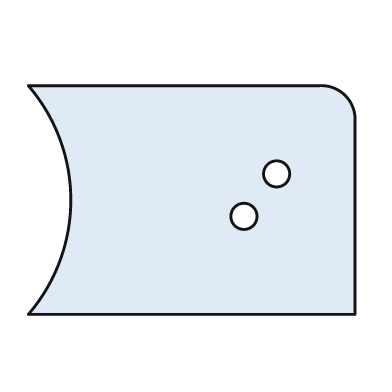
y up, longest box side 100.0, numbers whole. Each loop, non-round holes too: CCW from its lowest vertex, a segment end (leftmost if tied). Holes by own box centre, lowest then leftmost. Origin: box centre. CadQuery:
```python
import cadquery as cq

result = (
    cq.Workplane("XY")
    .moveTo(-50.0, -35.0)
    .lineTo(50.0, -35.0)
    .lineTo(50.0, 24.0)
    .threePointArc((47.0, 32.0), (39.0, 35.0))
    .lineTo(-50.0, 35.0)
    .threePointArc((-37.0, 0.0), (-50.0, -35.0))
    .close()
    .moveTo(16.0, -5.0)
    .circle(4.0)
    .moveTo(26.0, 8.0)
    .circle(4.0)
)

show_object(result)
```